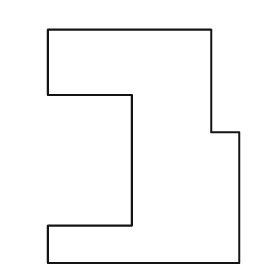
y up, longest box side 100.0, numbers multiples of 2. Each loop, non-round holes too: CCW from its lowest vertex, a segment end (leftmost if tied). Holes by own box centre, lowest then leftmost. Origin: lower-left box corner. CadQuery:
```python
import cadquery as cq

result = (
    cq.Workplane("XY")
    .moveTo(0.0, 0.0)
    .lineTo(82.0, 0.0)
    .lineTo(82.0, 56.0)
    .lineTo(70.0, 56.0)
    .lineTo(70.0, 100.0)
    .lineTo(0.0, 100.0)
    .lineTo(0.0, 72.0)
    .lineTo(36.0, 72.0)
    .lineTo(36.0, 16.0)
    .lineTo(0.0, 16.0)
    .close()
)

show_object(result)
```